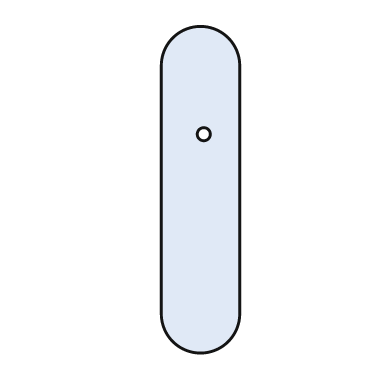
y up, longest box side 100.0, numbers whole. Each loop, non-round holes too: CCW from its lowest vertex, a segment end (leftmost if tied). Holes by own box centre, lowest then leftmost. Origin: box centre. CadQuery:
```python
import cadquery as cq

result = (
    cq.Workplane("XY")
    .moveTo(-12.0, -38.0)
    .threePointArc((0.0, -50.0), (12.0, -38.0))
    .lineTo(12.0, 38.0)
    .threePointArc((0.0, 50.0), (-12.0, 38.0))
    .close()
    .moveTo(1.0, 17.0)
    .circle(2.0)
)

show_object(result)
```